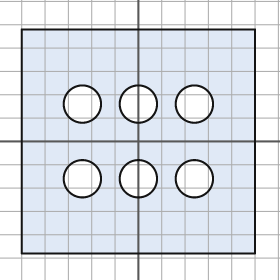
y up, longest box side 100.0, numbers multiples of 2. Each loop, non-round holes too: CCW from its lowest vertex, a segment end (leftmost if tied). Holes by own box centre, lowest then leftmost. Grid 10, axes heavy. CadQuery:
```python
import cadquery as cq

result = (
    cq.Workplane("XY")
    .moveTo(-50.0, -48.0)
    .lineTo(50.0, -48.0)
    .lineTo(50.0, 48.0)
    .lineTo(-50.0, 48.0)
    .close()
    .moveTo(-24.0, -16.0)
    .circle(8.0)
    .moveTo(0.0, -16.0)
    .circle(8.0)
    .moveTo(24.0, -16.0)
    .circle(8.0)
    .moveTo(-24.0, 16.0)
    .circle(8.0)
    .moveTo(0.0, 16.0)
    .circle(8.0)
    .moveTo(24.0, 16.0)
    .circle(8.0)
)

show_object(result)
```